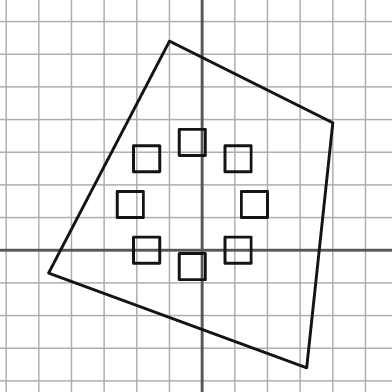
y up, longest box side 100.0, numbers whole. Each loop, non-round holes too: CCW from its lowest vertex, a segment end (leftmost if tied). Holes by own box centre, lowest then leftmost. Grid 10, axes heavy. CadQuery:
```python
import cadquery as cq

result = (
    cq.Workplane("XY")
    .moveTo(32.0, -36.0)
    .lineTo(40.0, 39.0)
    .lineTo(-10.0, 64.0)
    .lineTo(-47.0, -7.0)
    .close()
    .moveTo(-7.0, -9.0)
    .lineTo(1.0, -9.0)
    .lineTo(1.0, -1.0)
    .lineTo(-7.0, -1.0)
    .close()
    .moveTo(-21.0, -4.0)
    .lineTo(-13.0, -4.0)
    .lineTo(-13.0, 4.0)
    .lineTo(-21.0, 4.0)
    .close()
    .moveTo(7.0, -4.0)
    .lineTo(15.0, -4.0)
    .lineTo(15.0, 4.0)
    .lineTo(7.0, 4.0)
    .close()
    .moveTo(-26.0, 10.0)
    .lineTo(-18.0, 10.0)
    .lineTo(-18.0, 18.0)
    .lineTo(-26.0, 18.0)
    .close()
    .moveTo(12.0, 10.0)
    .lineTo(20.0, 10.0)
    .lineTo(20.0, 18.0)
    .lineTo(12.0, 18.0)
    .close()
    .moveTo(-21.0, 24.0)
    .lineTo(-13.0, 24.0)
    .lineTo(-13.0, 32.0)
    .lineTo(-21.0, 32.0)
    .close()
    .moveTo(7.0, 24.0)
    .lineTo(15.0, 24.0)
    .lineTo(15.0, 32.0)
    .lineTo(7.0, 32.0)
    .close()
    .moveTo(-7.0, 29.0)
    .lineTo(1.0, 29.0)
    .lineTo(1.0, 37.0)
    .lineTo(-7.0, 37.0)
    .close()
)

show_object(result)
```